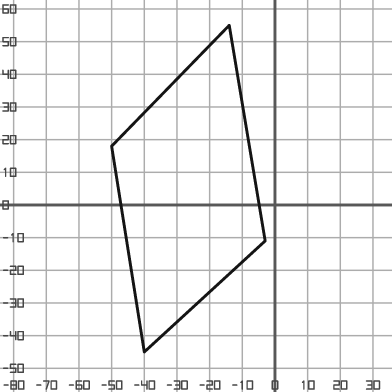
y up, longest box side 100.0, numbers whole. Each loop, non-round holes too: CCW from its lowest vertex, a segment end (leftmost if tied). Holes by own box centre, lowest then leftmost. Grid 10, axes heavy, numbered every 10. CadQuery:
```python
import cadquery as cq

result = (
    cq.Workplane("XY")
    .moveTo(-40.0, -45.0)
    .lineTo(-3.0, -11.0)
    .lineTo(-14.0, 55.0)
    .lineTo(-50.0, 18.0)
    .close()
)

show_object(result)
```